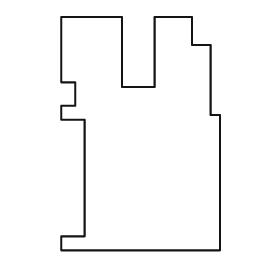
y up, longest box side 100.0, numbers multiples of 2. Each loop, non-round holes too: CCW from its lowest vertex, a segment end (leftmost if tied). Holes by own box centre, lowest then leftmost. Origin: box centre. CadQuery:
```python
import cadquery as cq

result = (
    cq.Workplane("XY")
    .moveTo(-34.0, -50.0)
    .lineTo(34.0, -50.0)
    .lineTo(34.0, 8.0)
    .lineTo(30.0, 8.0)
    .lineTo(30.0, 38.0)
    .lineTo(22.0, 38.0)
    .lineTo(22.0, 50.0)
    .lineTo(6.0, 50.0)
    .lineTo(6.0, 20.0)
    .lineTo(-8.0, 20.0)
    .lineTo(-8.0, 50.0)
    .lineTo(-34.0, 50.0)
    .lineTo(-34.0, 22.0)
    .lineTo(-28.0, 22.0)
    .lineTo(-28.0, 12.0)
    .lineTo(-34.0, 12.0)
    .lineTo(-34.0, 6.0)
    .lineTo(-24.0, 6.0)
    .lineTo(-24.0, -44.0)
    .lineTo(-34.0, -44.0)
    .close()
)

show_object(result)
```